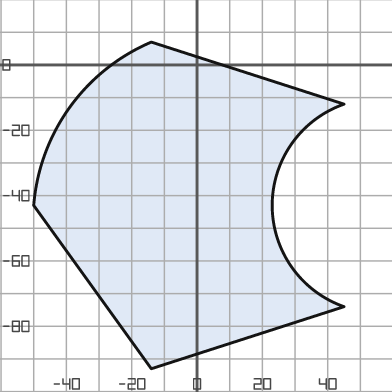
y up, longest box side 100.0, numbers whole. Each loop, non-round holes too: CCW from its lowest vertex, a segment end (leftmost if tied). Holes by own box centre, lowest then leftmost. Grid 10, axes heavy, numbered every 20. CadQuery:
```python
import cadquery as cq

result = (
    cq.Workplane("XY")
    .moveTo(-14.0, -93.0)
    .lineTo(45.0, -74.0)
    .threePointArc((23.0, -43.0), (45.0, -12.0))
    .lineTo(-14.0, 7.0)
    .threePointArc((-39.0, -13.0), (-50.0, -43.0))
    .close()
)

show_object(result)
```